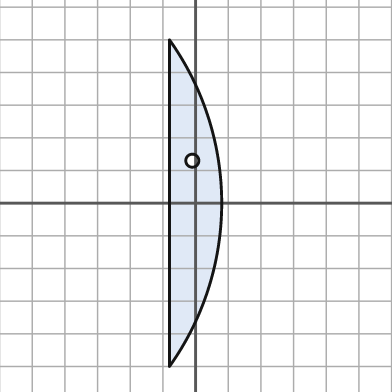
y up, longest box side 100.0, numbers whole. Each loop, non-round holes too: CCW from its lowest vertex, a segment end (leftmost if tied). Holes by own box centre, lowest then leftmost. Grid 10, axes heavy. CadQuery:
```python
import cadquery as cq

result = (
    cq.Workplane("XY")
    .moveTo(-8.0, -50.0)
    .threePointArc((8.0, 0.0), (-8.0, 50.0))
    .close()
    .moveTo(-1.0, 13.0)
    .circle(2.0)
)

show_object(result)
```